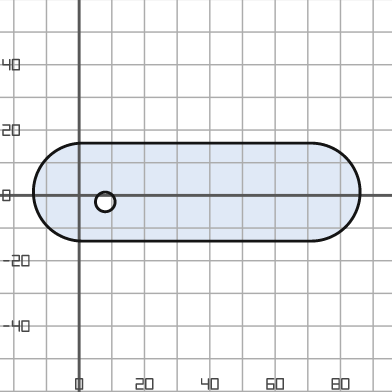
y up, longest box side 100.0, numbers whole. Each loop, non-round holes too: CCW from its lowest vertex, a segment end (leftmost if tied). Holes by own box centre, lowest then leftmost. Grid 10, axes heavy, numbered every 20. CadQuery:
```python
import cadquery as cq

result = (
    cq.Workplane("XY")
    .moveTo(1.0, -14.0)
    .lineTo(71.0, -14.0)
    .threePointArc((86.0, 1.0), (71.0, 16.0))
    .lineTo(1.0, 16.0)
    .threePointArc((-14.0, 1.0), (1.0, -14.0))
    .close()
    .moveTo(8.0, -2.0)
    .circle(3.0)
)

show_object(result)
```